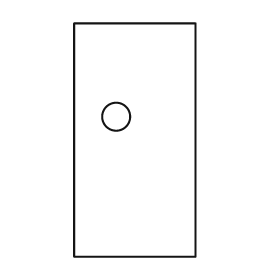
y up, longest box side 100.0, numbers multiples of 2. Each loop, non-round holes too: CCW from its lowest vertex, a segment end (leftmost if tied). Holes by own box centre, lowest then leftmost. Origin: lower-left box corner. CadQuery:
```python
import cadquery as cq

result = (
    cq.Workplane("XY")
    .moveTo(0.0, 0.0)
    .lineTo(52.0, 0.0)
    .lineTo(52.0, 100.0)
    .lineTo(0.0, 100.0)
    .close()
    .moveTo(18.0, 60.0)
    .circle(6.0)
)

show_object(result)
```